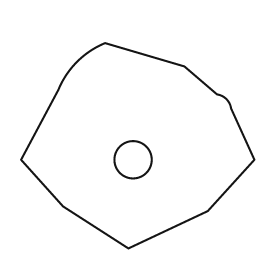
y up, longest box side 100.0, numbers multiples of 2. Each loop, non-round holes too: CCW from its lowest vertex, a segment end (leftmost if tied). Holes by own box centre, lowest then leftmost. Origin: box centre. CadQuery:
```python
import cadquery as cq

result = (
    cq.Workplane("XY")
    .moveTo(-4.0, -44.0)
    .lineTo(30.0, -28.0)
    .lineTo(50.0, -6.0)
    .lineTo(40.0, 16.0)
    .threePointArc((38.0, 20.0), (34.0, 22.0))
    .lineTo(20.0, 34.0)
    .lineTo(-14.0, 44.0)
    .threePointArc((-26.0, 36.0), (-34.0, 24.0))
    .lineTo(-50.0, -6.0)
    .lineTo(-32.0, -26.0)
    .close()
    .moveTo(-2.0, -6.0)
    .circle(8.0)
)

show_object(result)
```